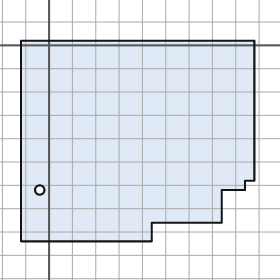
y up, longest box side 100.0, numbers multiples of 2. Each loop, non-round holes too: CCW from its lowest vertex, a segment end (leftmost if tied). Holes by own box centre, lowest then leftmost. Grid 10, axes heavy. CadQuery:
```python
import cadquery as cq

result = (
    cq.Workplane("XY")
    .moveTo(-12.0, -84.0)
    .lineTo(44.0, -84.0)
    .lineTo(44.0, -76.0)
    .lineTo(74.0, -76.0)
    .lineTo(74.0, -62.0)
    .lineTo(84.0, -62.0)
    .lineTo(84.0, -58.0)
    .lineTo(88.0, -58.0)
    .lineTo(88.0, 2.0)
    .lineTo(-12.0, 2.0)
    .close()
    .moveTo(-4.0, -62.0)
    .circle(2.0)
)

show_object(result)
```